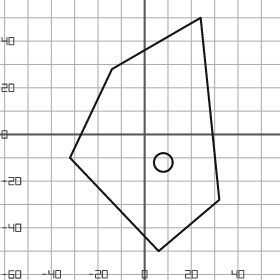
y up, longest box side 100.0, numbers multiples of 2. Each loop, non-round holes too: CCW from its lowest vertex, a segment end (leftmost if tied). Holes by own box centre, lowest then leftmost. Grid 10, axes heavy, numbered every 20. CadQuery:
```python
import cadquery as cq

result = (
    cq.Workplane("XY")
    .moveTo(6.0, -50.0)
    .lineTo(32.0, -28.0)
    .lineTo(24.0, 50.0)
    .lineTo(-14.0, 28.0)
    .lineTo(-32.0, -10.0)
    .close()
    .moveTo(8.0, -12.0)
    .circle(4.0)
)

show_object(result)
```